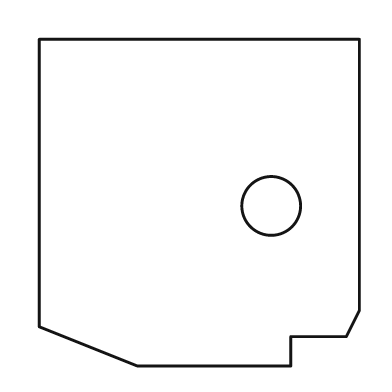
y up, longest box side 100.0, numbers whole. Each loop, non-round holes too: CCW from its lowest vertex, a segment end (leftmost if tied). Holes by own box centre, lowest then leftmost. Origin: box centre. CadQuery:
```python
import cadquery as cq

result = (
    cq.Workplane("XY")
    .moveTo(-19.0, -50.0)
    .lineTo(28.0, -50.0)
    .lineTo(28.0, -41.0)
    .lineTo(45.0, -41.0)
    .lineTo(49.0, -33.0)
    .lineTo(49.0, 50.0)
    .lineTo(-49.0, 50.0)
    .lineTo(-49.0, -38.0)
    .close()
    .moveTo(22.0, -1.0)
    .circle(9.0)
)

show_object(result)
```